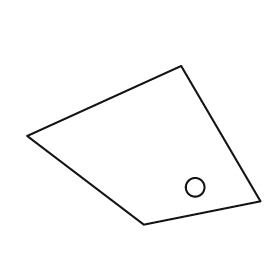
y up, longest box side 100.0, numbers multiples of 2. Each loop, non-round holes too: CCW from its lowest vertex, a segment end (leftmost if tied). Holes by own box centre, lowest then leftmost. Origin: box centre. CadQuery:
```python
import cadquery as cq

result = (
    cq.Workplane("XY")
    .moveTo(0.0, -34.0)
    .lineTo(50.0, -24.0)
    .lineTo(16.0, 34.0)
    .lineTo(-50.0, 4.0)
    .close()
    .moveTo(22.0, -18.0)
    .circle(4.0)
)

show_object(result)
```